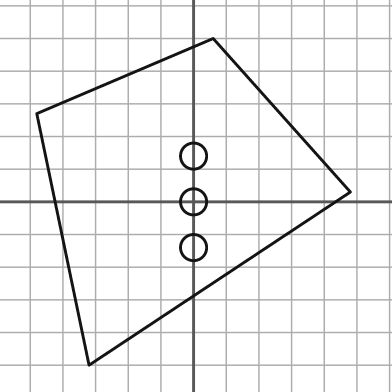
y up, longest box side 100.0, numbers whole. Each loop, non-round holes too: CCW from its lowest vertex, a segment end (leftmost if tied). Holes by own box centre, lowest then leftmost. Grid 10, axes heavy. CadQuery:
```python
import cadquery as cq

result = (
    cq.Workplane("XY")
    .moveTo(-32.0, -50.0)
    .lineTo(48.0, 3.0)
    .lineTo(6.0, 50.0)
    .lineTo(-48.0, 27.0)
    .close()
    .moveTo(0.0, -14.0)
    .circle(4.0)
    .moveTo(0.0, 0.0)
    .circle(4.0)
    .moveTo(0.0, 14.0)
    .circle(4.0)
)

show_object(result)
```